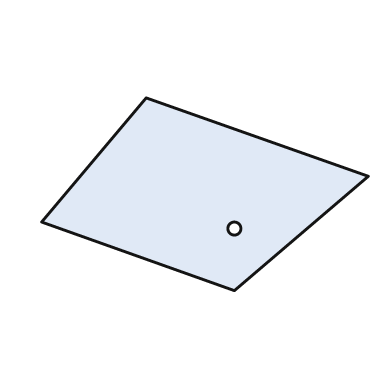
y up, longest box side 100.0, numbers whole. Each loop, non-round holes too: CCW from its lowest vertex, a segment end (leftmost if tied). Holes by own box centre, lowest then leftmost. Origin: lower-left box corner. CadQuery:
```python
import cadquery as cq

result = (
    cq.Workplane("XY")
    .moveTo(59.0, 0.0)
    .lineTo(100.0, 35.0)
    .lineTo(32.0, 59.0)
    .lineTo(0.0, 21.0)
    .close()
    .moveTo(59.0, 19.0)
    .circle(2.0)
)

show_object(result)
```